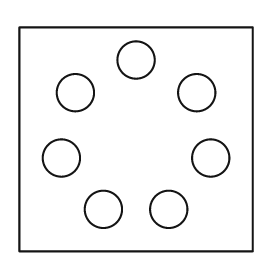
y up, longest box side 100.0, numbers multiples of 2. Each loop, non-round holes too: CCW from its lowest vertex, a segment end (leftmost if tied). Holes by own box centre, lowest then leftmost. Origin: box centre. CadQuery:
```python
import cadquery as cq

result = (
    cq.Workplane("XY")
    .moveTo(-50.0, -48.0)
    .lineTo(50.0, -48.0)
    .lineTo(50.0, 48.0)
    .lineTo(-50.0, 48.0)
    .close()
    .moveTo(-14.0, -30.0)
    .circle(8.0)
    .moveTo(14.0, -30.0)
    .circle(8.0)
    .moveTo(-32.0, -8.0)
    .circle(8.0)
    .moveTo(32.0, -8.0)
    .circle(8.0)
    .moveTo(-26.0, 20.0)
    .circle(8.0)
    .moveTo(26.0, 20.0)
    .circle(8.0)
    .moveTo(0.0, 34.0)
    .circle(8.0)
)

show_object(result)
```